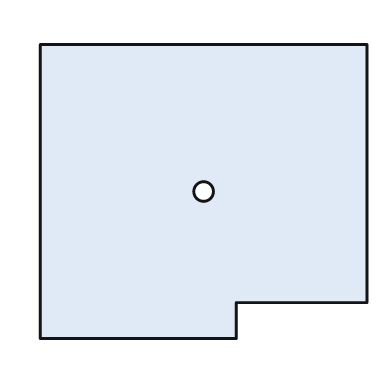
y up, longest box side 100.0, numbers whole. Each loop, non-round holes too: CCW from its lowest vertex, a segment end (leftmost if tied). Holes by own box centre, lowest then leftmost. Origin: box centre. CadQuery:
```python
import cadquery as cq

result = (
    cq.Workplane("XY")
    .moveTo(-50.0, -45.0)
    .lineTo(10.0, -45.0)
    .lineTo(10.0, -34.0)
    .lineTo(50.0, -34.0)
    .lineTo(50.0, 45.0)
    .lineTo(-50.0, 45.0)
    .close()
    .moveTo(0.0, 0.0)
    .circle(3.0)
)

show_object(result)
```